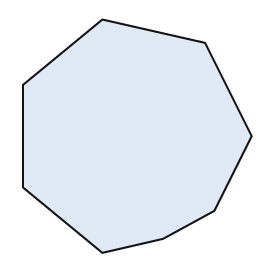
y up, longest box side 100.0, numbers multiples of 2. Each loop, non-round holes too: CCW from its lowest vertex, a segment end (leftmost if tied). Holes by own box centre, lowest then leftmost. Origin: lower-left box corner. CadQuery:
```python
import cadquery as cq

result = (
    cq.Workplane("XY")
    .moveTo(34.0, 0.0)
    .lineTo(60.0, 6.0)
    .lineTo(82.0, 18.0)
    .lineTo(98.0, 50.0)
    .lineTo(78.0, 90.0)
    .lineTo(34.0, 100.0)
    .lineTo(0.0, 72.0)
    .lineTo(0.0, 28.0)
    .close()
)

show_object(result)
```